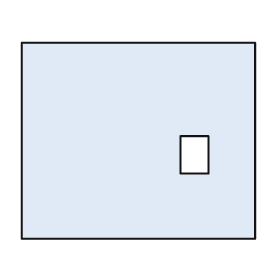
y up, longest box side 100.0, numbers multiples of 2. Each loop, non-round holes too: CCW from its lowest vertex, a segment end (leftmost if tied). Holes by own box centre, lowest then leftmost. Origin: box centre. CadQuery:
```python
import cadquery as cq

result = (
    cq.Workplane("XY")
    .moveTo(-50.0, -42.0)
    .lineTo(50.0, -42.0)
    .lineTo(50.0, 42.0)
    .lineTo(-50.0, 42.0)
    .close()
    .moveTo(18.0, -14.0)
    .lineTo(30.0, -14.0)
    .lineTo(30.0, 2.0)
    .lineTo(18.0, 2.0)
    .close()
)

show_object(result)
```